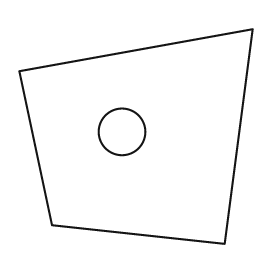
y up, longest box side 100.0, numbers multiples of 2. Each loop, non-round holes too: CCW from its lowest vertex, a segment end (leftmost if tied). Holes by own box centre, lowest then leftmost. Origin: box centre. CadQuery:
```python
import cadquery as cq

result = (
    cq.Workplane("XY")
    .moveTo(38.0, -46.0)
    .lineTo(50.0, 46.0)
    .lineTo(-50.0, 28.0)
    .lineTo(-36.0, -38.0)
    .close()
    .moveTo(-6.0, 2.0)
    .circle(10.0)
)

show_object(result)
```